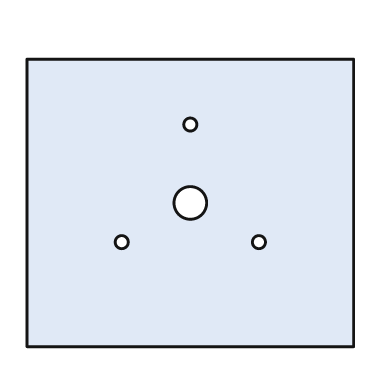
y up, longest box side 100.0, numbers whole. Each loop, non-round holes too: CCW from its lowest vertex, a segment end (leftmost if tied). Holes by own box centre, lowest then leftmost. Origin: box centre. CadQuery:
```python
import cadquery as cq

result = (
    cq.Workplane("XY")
    .moveTo(-50.0, -44.0)
    .lineTo(50.0, -44.0)
    .lineTo(50.0, 44.0)
    .lineTo(-50.0, 44.0)
    .close()
    .moveTo(-21.0, -12.0)
    .circle(2.0)
    .moveTo(21.0, -12.0)
    .circle(2.0)
    .moveTo(0.0, 0.0)
    .circle(5.0)
    .moveTo(0.0, 24.0)
    .circle(2.0)
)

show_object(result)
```